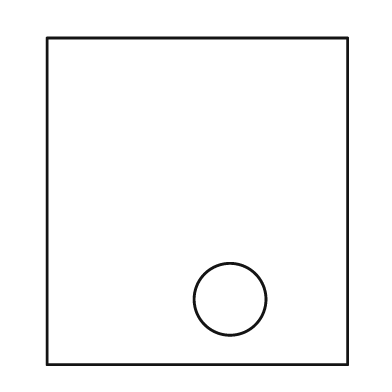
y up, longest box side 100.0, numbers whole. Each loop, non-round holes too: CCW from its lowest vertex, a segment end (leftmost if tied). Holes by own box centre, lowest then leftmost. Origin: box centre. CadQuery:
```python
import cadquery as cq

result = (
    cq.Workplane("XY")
    .moveTo(-46.0, -50.0)
    .lineTo(46.0, -50.0)
    .lineTo(46.0, 50.0)
    .lineTo(-46.0, 50.0)
    .close()
    .moveTo(10.0, -30.0)
    .circle(11.0)
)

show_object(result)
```